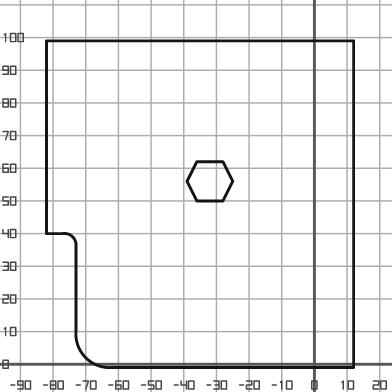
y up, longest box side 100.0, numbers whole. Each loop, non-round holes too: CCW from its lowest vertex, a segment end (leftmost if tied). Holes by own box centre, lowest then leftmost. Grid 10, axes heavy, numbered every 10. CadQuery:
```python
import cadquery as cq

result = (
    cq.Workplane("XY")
    .moveTo(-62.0, -1.0)
    .lineTo(12.0, -1.0)
    .lineTo(12.0, 99.0)
    .lineTo(-82.0, 99.0)
    .lineTo(-82.0, 40.0)
    .lineTo(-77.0, 40.0)
    .threePointArc((-74.0, 39.0), (-73.0, 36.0))
    .lineTo(-73.0, 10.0)
    .threePointArc((-70.0, 2.0), (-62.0, -1.0))
    .close()
    .moveTo(-36.0, 50.0)
    .lineTo(-28.0, 50.0)
    .lineTo(-25.0, 56.0)
    .lineTo(-28.0, 62.0)
    .lineTo(-36.0, 62.0)
    .lineTo(-39.0, 56.0)
    .close()
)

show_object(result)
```